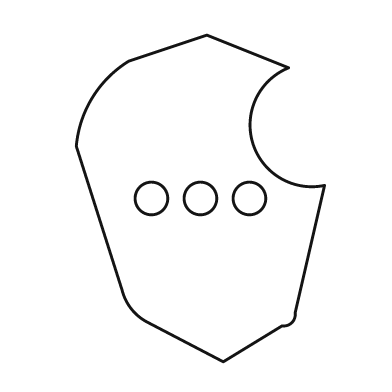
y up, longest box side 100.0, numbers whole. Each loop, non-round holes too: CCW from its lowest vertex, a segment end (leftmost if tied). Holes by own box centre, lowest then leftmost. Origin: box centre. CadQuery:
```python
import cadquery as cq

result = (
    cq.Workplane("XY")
    .moveTo(7.0, -50.0)
    .lineTo(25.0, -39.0)
    .threePointArc((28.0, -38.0), (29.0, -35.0))
    .lineTo(38.0, 4.0)
    .threePointArc((16.0, 17.0), (27.0, 40.0))
    .lineTo(2.0, 50.0)
    .lineTo(-22.0, 42.0)
    .threePointArc((-33.0, 31.0), (-38.0, 16.0))
    .lineTo(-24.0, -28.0)
    .threePointArc((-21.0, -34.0), (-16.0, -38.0))
    .close()
    .moveTo(-15.0, 0.0)
    .circle(5.0)
    .moveTo(0.0, 0.0)
    .circle(5.0)
    .moveTo(15.0, 0.0)
    .circle(5.0)
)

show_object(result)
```